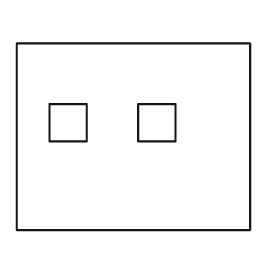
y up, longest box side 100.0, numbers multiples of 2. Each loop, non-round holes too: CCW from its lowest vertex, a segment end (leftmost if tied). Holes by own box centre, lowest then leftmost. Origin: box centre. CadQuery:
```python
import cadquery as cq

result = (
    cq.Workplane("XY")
    .moveTo(-50.0, -40.0)
    .lineTo(50.0, -40.0)
    .lineTo(50.0, 40.0)
    .lineTo(-50.0, 40.0)
    .close()
    .moveTo(-36.0, -2.0)
    .lineTo(-20.0, -2.0)
    .lineTo(-20.0, 14.0)
    .lineTo(-36.0, 14.0)
    .close()
    .moveTo(2.0, -2.0)
    .lineTo(18.0, -2.0)
    .lineTo(18.0, 14.0)
    .lineTo(2.0, 14.0)
    .close()
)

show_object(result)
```